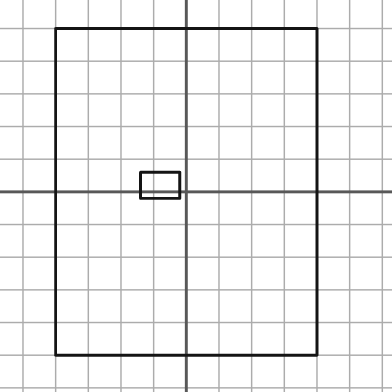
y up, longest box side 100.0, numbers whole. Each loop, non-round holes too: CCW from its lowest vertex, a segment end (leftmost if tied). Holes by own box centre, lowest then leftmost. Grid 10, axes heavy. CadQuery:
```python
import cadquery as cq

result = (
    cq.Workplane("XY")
    .moveTo(-40.0, -50.0)
    .lineTo(40.0, -50.0)
    .lineTo(40.0, 50.0)
    .lineTo(-40.0, 50.0)
    .close()
    .moveTo(-14.0, -2.0)
    .lineTo(-2.0, -2.0)
    .lineTo(-2.0, 6.0)
    .lineTo(-14.0, 6.0)
    .close()
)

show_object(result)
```